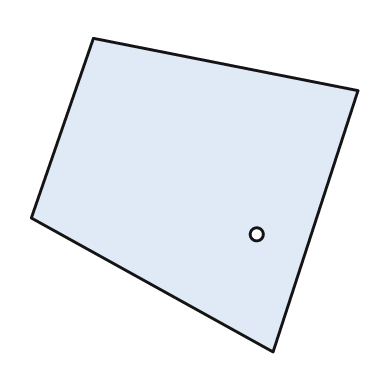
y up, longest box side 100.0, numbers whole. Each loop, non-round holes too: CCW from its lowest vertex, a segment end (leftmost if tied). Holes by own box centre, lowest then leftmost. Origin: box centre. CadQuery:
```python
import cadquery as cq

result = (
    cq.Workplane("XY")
    .moveTo(24.0, -48.0)
    .lineTo(50.0, 32.0)
    .lineTo(-31.0, 48.0)
    .lineTo(-50.0, -7.0)
    .close()
    .moveTo(19.0, -12.0)
    .circle(2.0)
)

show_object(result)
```